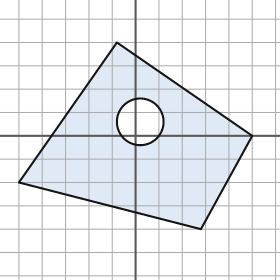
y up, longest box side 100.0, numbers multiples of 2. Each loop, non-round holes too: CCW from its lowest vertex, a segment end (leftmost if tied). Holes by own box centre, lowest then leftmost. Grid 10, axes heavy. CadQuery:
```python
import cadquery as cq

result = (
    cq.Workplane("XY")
    .moveTo(28.0, -40.0)
    .lineTo(50.0, 0.0)
    .lineTo(-8.0, 40.0)
    .lineTo(-50.0, -20.0)
    .close()
    .moveTo(2.0, 6.0)
    .circle(10.0)
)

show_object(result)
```